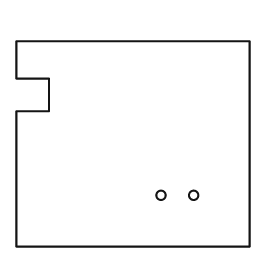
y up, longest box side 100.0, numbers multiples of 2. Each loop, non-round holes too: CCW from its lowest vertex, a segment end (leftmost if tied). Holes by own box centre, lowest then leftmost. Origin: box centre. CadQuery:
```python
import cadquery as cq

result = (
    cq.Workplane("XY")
    .moveTo(-50.0, -44.0)
    .lineTo(50.0, -44.0)
    .lineTo(50.0, 44.0)
    .lineTo(-50.0, 44.0)
    .lineTo(-50.0, 28.0)
    .lineTo(-36.0, 28.0)
    .lineTo(-36.0, 14.0)
    .lineTo(-50.0, 14.0)
    .close()
    .moveTo(12.0, -22.0)
    .circle(2.0)
    .moveTo(26.0, -22.0)
    .circle(2.0)
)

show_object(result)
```